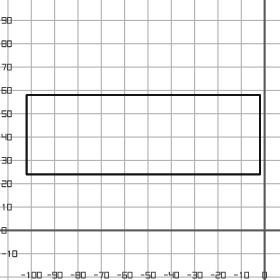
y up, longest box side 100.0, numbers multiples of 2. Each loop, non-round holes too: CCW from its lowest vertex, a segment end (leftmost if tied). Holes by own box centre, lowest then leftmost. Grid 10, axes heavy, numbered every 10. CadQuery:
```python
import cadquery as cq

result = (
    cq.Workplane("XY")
    .moveTo(-102.0, 24.0)
    .lineTo(-2.0, 24.0)
    .lineTo(-2.0, 58.0)
    .lineTo(-102.0, 58.0)
    .close()
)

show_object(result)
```